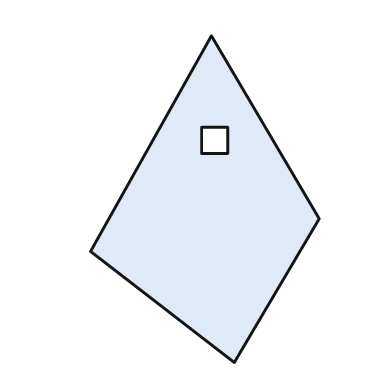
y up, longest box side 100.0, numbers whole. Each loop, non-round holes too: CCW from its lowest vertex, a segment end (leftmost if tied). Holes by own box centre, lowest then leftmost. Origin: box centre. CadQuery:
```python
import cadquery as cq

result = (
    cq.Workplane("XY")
    .moveTo(9.0, -50.0)
    .lineTo(35.0, -6.0)
    .lineTo(2.0, 50.0)
    .lineTo(-35.0, -16.0)
    .close()
    .moveTo(-1.0, 14.0)
    .lineTo(7.0, 14.0)
    .lineTo(7.0, 22.0)
    .lineTo(-1.0, 22.0)
    .close()
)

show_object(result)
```